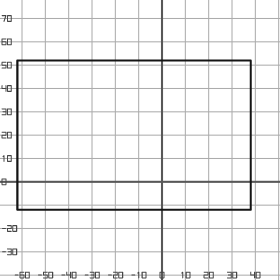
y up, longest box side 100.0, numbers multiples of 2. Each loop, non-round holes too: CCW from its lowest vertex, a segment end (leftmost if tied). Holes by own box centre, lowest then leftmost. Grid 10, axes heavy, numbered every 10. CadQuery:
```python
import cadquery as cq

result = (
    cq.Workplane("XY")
    .moveTo(-62.0, -12.0)
    .lineTo(38.0, -12.0)
    .lineTo(38.0, 52.0)
    .lineTo(-62.0, 52.0)
    .close()
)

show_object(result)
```